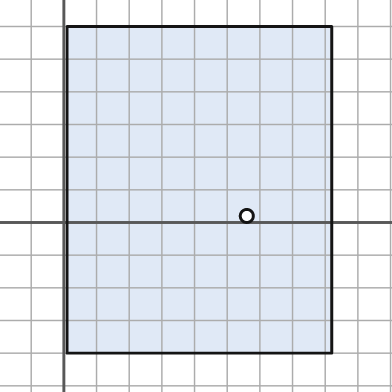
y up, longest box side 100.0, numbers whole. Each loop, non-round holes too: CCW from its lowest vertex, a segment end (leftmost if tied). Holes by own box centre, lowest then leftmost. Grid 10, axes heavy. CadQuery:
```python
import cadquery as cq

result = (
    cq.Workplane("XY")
    .moveTo(1.0, -40.0)
    .lineTo(82.0, -40.0)
    .lineTo(82.0, 60.0)
    .lineTo(1.0, 60.0)
    .close()
    .moveTo(56.0, 2.0)
    .circle(2.0)
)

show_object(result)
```